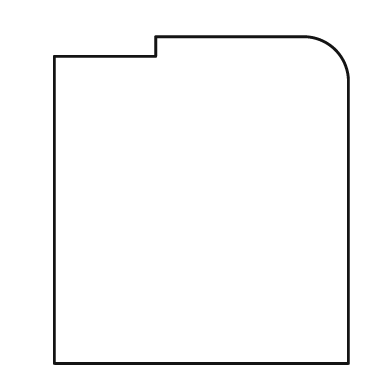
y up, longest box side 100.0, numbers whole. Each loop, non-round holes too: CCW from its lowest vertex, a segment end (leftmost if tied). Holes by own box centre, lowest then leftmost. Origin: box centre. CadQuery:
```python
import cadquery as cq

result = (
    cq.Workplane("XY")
    .moveTo(-45.0, -50.0)
    .lineTo(45.0, -50.0)
    .lineTo(45.0, 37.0)
    .threePointArc((41.0, 46.0), (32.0, 50.0))
    .lineTo(-14.0, 50.0)
    .lineTo(-14.0, 44.0)
    .lineTo(-45.0, 44.0)
    .close()
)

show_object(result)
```